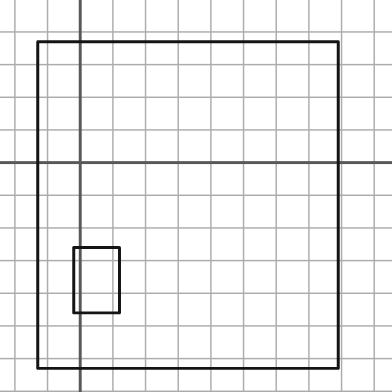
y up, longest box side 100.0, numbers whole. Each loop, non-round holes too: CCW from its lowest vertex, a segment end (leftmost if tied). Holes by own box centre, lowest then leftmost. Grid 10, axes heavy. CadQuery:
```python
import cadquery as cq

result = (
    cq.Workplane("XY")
    .moveTo(-13.0, -63.0)
    .lineTo(79.0, -63.0)
    .lineTo(79.0, 37.0)
    .lineTo(-13.0, 37.0)
    .close()
    .moveTo(-2.0, -46.0)
    .lineTo(12.0, -46.0)
    .lineTo(12.0, -26.0)
    .lineTo(-2.0, -26.0)
    .close()
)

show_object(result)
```